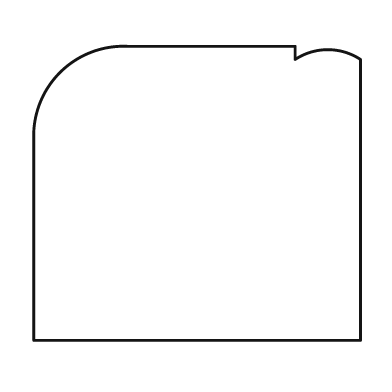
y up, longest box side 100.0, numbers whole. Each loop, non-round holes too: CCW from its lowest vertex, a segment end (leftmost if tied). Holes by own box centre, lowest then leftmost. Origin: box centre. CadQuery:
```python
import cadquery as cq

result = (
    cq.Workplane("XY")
    .moveTo(-50.0, -45.0)
    .lineTo(50.0, -45.0)
    .lineTo(50.0, 41.0)
    .threePointArc((40.0, 44.0), (30.0, 41.0))
    .lineTo(30.0, 45.0)
    .lineTo(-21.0, 45.0)
    .threePointArc((-42.0, 37.0), (-50.0, 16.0))
    .close()
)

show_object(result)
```